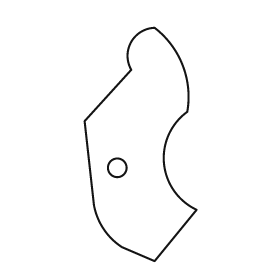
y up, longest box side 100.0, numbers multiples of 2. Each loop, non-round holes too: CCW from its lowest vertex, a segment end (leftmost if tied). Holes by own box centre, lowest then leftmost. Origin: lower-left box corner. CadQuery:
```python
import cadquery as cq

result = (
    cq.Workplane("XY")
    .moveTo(30.0, 0.0)
    .lineTo(48.0, 22.0)
    .threePointArc((34.0, 42.0), (44.0, 64.0))
    .threePointArc((42.0, 84.0), (30.0, 100.0))
    .threePointArc((20.0, 94.0), (20.0, 82.0))
    .lineTo(0.0, 60.0)
    .lineTo(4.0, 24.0)
    .threePointArc((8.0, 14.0), (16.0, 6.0))
    .close()
    .moveTo(14.0, 40.0)
    .circle(4.0)
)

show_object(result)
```